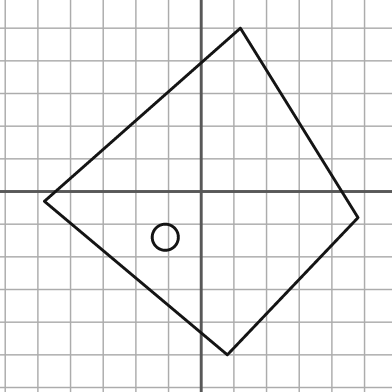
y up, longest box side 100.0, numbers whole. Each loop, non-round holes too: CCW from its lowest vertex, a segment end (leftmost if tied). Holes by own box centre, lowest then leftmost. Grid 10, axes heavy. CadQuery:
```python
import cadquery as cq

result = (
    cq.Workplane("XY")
    .moveTo(8.0, -50.0)
    .lineTo(48.0, -8.0)
    .lineTo(12.0, 50.0)
    .lineTo(-48.0, -3.0)
    .close()
    .moveTo(-11.0, -14.0)
    .circle(4.0)
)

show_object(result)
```